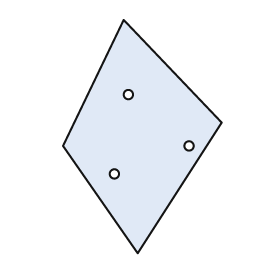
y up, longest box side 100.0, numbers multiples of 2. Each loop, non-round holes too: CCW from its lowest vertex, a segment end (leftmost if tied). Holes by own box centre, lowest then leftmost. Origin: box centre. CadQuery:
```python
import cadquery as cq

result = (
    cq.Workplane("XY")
    .moveTo(-2.0, -50.0)
    .lineTo(34.0, 6.0)
    .lineTo(-8.0, 50.0)
    .lineTo(-34.0, -4.0)
    .close()
    .moveTo(-12.0, -16.0)
    .circle(2.0)
    .moveTo(20.0, -4.0)
    .circle(2.0)
    .moveTo(-6.0, 18.0)
    .circle(2.0)
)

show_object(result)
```